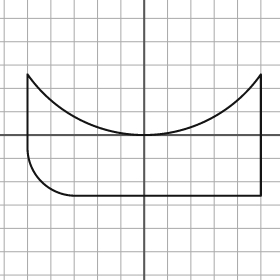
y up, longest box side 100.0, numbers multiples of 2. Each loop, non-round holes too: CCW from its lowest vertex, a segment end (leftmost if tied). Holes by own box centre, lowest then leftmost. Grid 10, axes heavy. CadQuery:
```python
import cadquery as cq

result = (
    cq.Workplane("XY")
    .moveTo(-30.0, -26.0)
    .lineTo(50.0, -26.0)
    .lineTo(50.0, 26.0)
    .threePointArc((0.0, 0.0), (-50.0, 26.0))
    .lineTo(-50.0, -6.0)
    .threePointArc((-44.0, -20.0), (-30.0, -26.0))
    .close()
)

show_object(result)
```